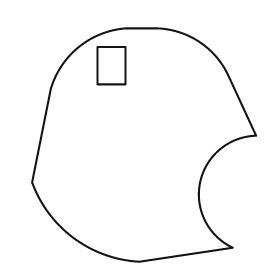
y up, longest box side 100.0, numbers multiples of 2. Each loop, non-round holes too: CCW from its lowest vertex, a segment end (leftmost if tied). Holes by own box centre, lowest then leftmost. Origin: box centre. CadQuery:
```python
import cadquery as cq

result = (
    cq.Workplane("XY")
    .moveTo(-2.0, -50.0)
    .lineTo(38.0, -44.0)
    .threePointArc((24.0, -16.0), (48.0, 4.0))
    .lineTo(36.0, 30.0)
    .threePointArc((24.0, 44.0), (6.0, 50.0))
    .lineTo(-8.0, 50.0)
    .threePointArc((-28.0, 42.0), (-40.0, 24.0))
    .lineTo(-48.0, -16.0)
    .threePointArc((-30.0, -40.0), (-2.0, -50.0))
    .close()
    .moveTo(-20.0, 26.0)
    .lineTo(-8.0, 26.0)
    .lineTo(-8.0, 42.0)
    .lineTo(-20.0, 42.0)
    .close()
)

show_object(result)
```